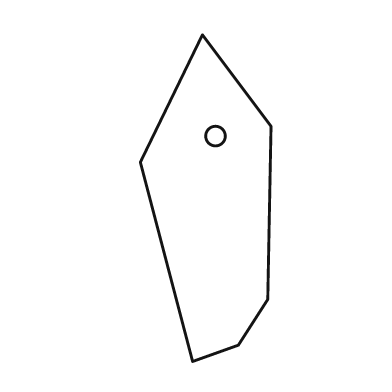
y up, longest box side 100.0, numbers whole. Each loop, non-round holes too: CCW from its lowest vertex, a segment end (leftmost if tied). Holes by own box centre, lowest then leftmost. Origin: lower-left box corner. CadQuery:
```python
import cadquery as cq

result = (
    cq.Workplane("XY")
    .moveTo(16.0, 0.0)
    .lineTo(30.0, 5.0)
    .lineTo(39.0, 19.0)
    .lineTo(40.0, 72.0)
    .lineTo(19.0, 100.0)
    .lineTo(0.0, 61.0)
    .close()
    .moveTo(23.0, 69.0)
    .circle(3.0)
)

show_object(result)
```